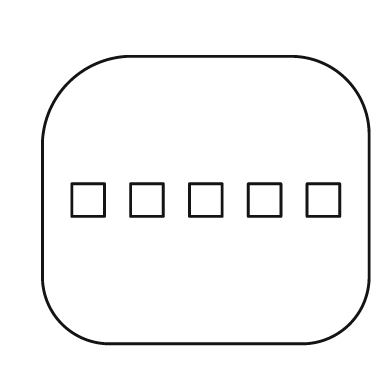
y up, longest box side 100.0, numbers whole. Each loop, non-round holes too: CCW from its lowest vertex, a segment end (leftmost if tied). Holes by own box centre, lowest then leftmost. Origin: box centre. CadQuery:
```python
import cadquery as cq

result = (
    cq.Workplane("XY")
    .moveTo(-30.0, -44.0)
    .lineTo(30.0, -44.0)
    .threePointArc((44.0, -38.0), (50.0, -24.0))
    .lineTo(50.0, 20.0)
    .threePointArc((43.0, 37.0), (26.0, 44.0))
    .lineTo(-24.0, 44.0)
    .threePointArc((-42.0, 36.0), (-50.0, 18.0))
    .lineTo(-50.0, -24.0)
    .threePointArc((-44.0, -38.0), (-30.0, -44.0))
    .close()
    .moveTo(-41.0, -5.0)
    .lineTo(-31.0, -5.0)
    .lineTo(-31.0, 5.0)
    .lineTo(-41.0, 5.0)
    .close()
    .moveTo(-23.0, -5.0)
    .lineTo(-13.0, -5.0)
    .lineTo(-13.0, 5.0)
    .lineTo(-23.0, 5.0)
    .close()
    .moveTo(-5.0, -5.0)
    .lineTo(5.0, -5.0)
    .lineTo(5.0, 5.0)
    .lineTo(-5.0, 5.0)
    .close()
    .moveTo(13.0, -5.0)
    .lineTo(23.0, -5.0)
    .lineTo(23.0, 5.0)
    .lineTo(13.0, 5.0)
    .close()
    .moveTo(31.0, -5.0)
    .lineTo(41.0, -5.0)
    .lineTo(41.0, 5.0)
    .lineTo(31.0, 5.0)
    .close()
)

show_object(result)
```